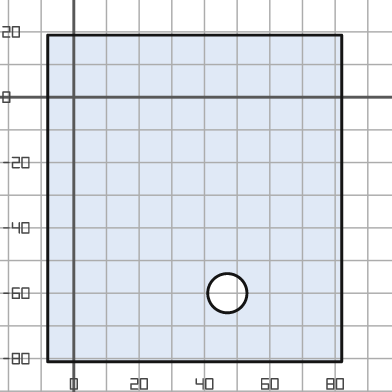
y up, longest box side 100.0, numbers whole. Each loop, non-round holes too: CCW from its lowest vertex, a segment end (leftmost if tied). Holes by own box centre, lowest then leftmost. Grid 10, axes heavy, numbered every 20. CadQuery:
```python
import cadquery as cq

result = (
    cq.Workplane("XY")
    .moveTo(-8.0, -81.0)
    .lineTo(82.0, -81.0)
    .lineTo(82.0, 19.0)
    .lineTo(-8.0, 19.0)
    .close()
    .moveTo(47.0, -60.0)
    .circle(6.0)
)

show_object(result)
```